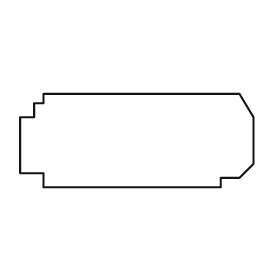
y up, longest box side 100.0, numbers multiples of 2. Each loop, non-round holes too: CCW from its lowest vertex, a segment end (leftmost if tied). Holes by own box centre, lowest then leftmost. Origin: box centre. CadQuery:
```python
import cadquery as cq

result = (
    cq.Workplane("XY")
    .moveTo(-40.0, -20.0)
    .lineTo(36.0, -20.0)
    .lineTo(36.0, -16.0)
    .lineTo(44.0, -16.0)
    .lineTo(50.0, -10.0)
    .lineTo(50.0, 10.0)
    .lineTo(44.0, 20.0)
    .lineTo(-40.0, 20.0)
    .lineTo(-40.0, 16.0)
    .lineTo(-44.0, 16.0)
    .lineTo(-44.0, 10.0)
    .lineTo(-50.0, 10.0)
    .lineTo(-50.0, -14.0)
    .lineTo(-40.0, -14.0)
    .close()
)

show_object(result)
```